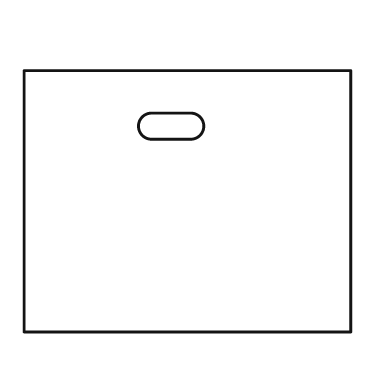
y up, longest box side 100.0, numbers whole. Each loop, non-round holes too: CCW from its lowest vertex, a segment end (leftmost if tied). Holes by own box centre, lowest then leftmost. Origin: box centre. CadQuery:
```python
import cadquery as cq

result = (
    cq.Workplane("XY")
    .moveTo(-50.0, -40.0)
    .lineTo(50.0, -40.0)
    .lineTo(50.0, 40.0)
    .lineTo(-50.0, 40.0)
    .close()
    .moveTo(-11.0, 19.0)
    .lineTo(1.0, 19.0)
    .threePointArc((5.0, 23.0), (1.0, 27.0))
    .lineTo(-11.0, 27.0)
    .threePointArc((-15.0, 23.0), (-11.0, 19.0))
    .close()
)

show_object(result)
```